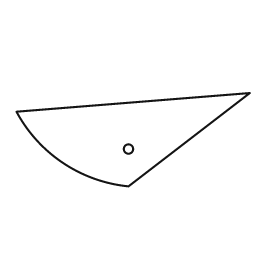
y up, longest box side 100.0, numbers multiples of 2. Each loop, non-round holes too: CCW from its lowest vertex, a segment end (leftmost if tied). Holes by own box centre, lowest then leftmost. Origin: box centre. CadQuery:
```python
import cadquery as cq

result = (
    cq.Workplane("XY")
    .moveTo(-2.0, -20.0)
    .lineTo(50.0, 20.0)
    .lineTo(-50.0, 12.0)
    .threePointArc((-30.0, -10.0), (-2.0, -20.0))
    .close()
    .moveTo(-2.0, -4.0)
    .circle(2.0)
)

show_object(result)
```